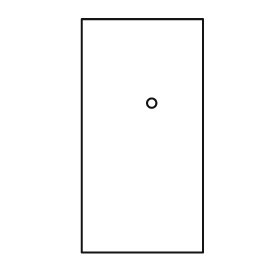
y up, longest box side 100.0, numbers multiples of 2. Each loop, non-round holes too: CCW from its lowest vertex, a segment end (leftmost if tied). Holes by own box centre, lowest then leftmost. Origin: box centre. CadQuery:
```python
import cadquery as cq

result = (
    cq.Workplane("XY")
    .moveTo(-26.0, -50.0)
    .lineTo(26.0, -50.0)
    .lineTo(26.0, 50.0)
    .lineTo(-26.0, 50.0)
    .close()
    .moveTo(4.0, 14.0)
    .circle(2.0)
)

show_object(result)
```